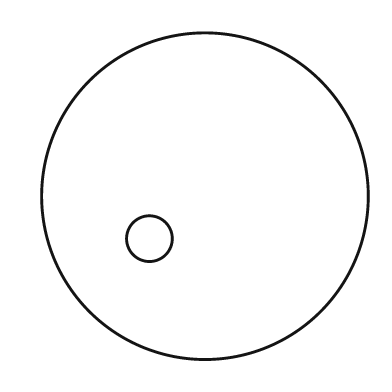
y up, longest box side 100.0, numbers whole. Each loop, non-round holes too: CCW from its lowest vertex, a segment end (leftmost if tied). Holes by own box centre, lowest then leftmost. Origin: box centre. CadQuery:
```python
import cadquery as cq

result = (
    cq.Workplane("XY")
    .moveTo(0.0, 0.0)
    .circle(50.0)
    .moveTo(-17.0, -13.0)
    .circle(7.0)
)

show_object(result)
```